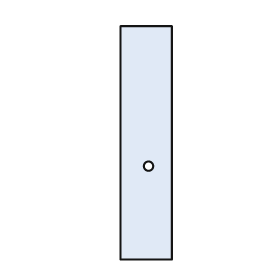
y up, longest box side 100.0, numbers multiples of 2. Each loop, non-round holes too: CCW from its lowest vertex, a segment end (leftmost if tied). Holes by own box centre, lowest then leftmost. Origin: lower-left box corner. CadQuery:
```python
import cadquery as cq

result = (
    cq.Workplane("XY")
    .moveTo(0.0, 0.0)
    .lineTo(22.0, 0.0)
    .lineTo(22.0, 100.0)
    .lineTo(0.0, 100.0)
    .close()
    .moveTo(12.0, 40.0)
    .circle(2.0)
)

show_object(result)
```